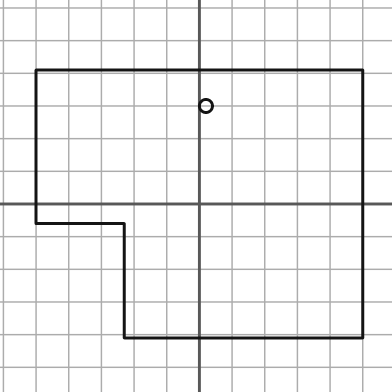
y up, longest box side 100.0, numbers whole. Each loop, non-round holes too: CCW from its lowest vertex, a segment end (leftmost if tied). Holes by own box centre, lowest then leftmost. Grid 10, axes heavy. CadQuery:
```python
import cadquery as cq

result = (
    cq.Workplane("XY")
    .moveTo(-23.0, -41.0)
    .lineTo(50.0, -41.0)
    .lineTo(50.0, 41.0)
    .lineTo(-50.0, 41.0)
    .lineTo(-50.0, -6.0)
    .lineTo(-23.0, -6.0)
    .close()
    .moveTo(2.0, 30.0)
    .circle(2.0)
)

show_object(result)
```